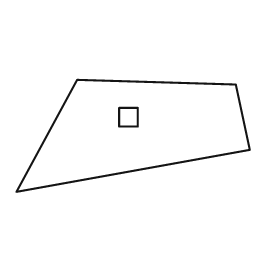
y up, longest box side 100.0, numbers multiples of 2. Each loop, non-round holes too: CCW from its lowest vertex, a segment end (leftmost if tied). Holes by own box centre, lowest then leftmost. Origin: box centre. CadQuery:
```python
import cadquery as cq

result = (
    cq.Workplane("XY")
    .moveTo(-50.0, -24.0)
    .lineTo(50.0, -6.0)
    .lineTo(44.0, 22.0)
    .lineTo(-24.0, 24.0)
    .close()
    .moveTo(-6.0, 4.0)
    .lineTo(2.0, 4.0)
    .lineTo(2.0, 12.0)
    .lineTo(-6.0, 12.0)
    .close()
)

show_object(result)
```